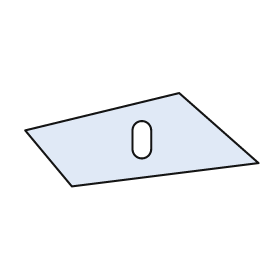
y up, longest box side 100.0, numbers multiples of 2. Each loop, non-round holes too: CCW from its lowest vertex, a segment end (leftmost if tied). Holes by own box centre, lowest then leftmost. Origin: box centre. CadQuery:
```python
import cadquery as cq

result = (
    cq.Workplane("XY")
    .moveTo(-30.0, -20.0)
    .lineTo(50.0, -10.0)
    .lineTo(16.0, 20.0)
    .lineTo(-50.0, 4.0)
    .close()
    .moveTo(-4.0, -4.0)
    .threePointArc((0.0, -8.0), (4.0, -4.0))
    .lineTo(4.0, 4.0)
    .threePointArc((0.0, 8.0), (-4.0, 4.0))
    .close()
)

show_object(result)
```